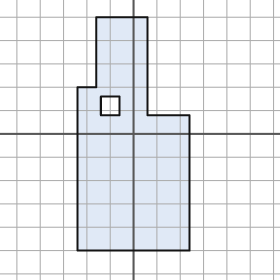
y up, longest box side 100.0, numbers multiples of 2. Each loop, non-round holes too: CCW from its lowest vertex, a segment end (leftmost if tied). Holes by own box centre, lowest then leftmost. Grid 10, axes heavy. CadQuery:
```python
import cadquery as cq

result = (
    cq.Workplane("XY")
    .moveTo(-24.0, -50.0)
    .lineTo(24.0, -50.0)
    .lineTo(24.0, 8.0)
    .lineTo(6.0, 8.0)
    .lineTo(6.0, 50.0)
    .lineTo(-16.0, 50.0)
    .lineTo(-16.0, 20.0)
    .lineTo(-24.0, 20.0)
    .close()
    .moveTo(-14.0, 8.0)
    .lineTo(-6.0, 8.0)
    .lineTo(-6.0, 16.0)
    .lineTo(-14.0, 16.0)
    .close()
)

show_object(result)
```